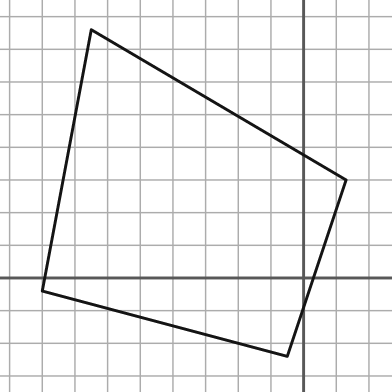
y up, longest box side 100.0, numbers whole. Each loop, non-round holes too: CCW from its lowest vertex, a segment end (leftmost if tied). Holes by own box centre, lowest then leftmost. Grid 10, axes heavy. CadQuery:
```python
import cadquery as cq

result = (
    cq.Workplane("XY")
    .moveTo(-5.0, -24.0)
    .lineTo(13.0, 30.0)
    .lineTo(-65.0, 76.0)
    .lineTo(-80.0, -4.0)
    .close()
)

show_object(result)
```